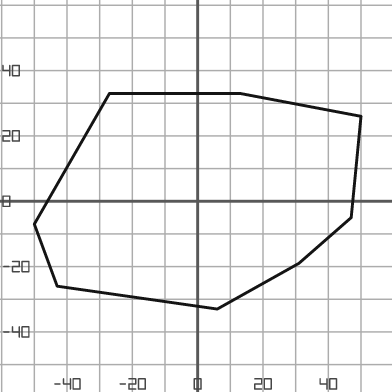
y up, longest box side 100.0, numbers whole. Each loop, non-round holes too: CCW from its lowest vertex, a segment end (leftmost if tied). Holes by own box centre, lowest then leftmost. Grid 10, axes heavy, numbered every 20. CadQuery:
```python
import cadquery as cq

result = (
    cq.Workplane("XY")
    .moveTo(6.0, -33.0)
    .lineTo(31.0, -19.0)
    .lineTo(47.0, -5.0)
    .lineTo(50.0, 26.0)
    .lineTo(13.0, 33.0)
    .lineTo(-27.0, 33.0)
    .lineTo(-50.0, -7.0)
    .lineTo(-43.0, -26.0)
    .close()
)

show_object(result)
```